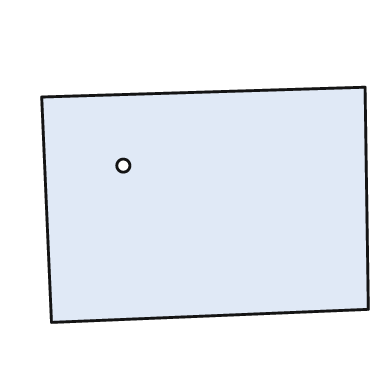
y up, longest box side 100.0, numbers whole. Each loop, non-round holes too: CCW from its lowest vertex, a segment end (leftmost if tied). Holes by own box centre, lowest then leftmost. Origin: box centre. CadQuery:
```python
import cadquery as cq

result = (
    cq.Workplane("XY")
    .moveTo(-47.0, -36.0)
    .lineTo(50.0, -32.0)
    .lineTo(49.0, 36.0)
    .lineTo(-50.0, 33.0)
    .close()
    .moveTo(-25.0, 12.0)
    .circle(2.0)
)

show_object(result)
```